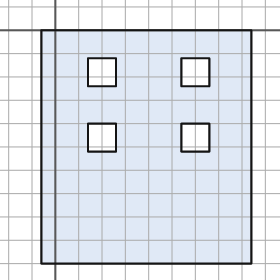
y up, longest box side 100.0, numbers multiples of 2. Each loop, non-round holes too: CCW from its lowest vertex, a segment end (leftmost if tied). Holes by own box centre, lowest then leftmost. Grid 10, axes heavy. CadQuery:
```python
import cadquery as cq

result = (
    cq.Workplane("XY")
    .moveTo(-6.0, -100.0)
    .lineTo(84.0, -100.0)
    .lineTo(84.0, 0.0)
    .lineTo(-6.0, 0.0)
    .close()
    .moveTo(14.0, -52.0)
    .lineTo(26.0, -52.0)
    .lineTo(26.0, -40.0)
    .lineTo(14.0, -40.0)
    .close()
    .moveTo(54.0, -52.0)
    .lineTo(66.0, -52.0)
    .lineTo(66.0, -40.0)
    .lineTo(54.0, -40.0)
    .close()
    .moveTo(14.0, -24.0)
    .lineTo(26.0, -24.0)
    .lineTo(26.0, -12.0)
    .lineTo(14.0, -12.0)
    .close()
    .moveTo(54.0, -24.0)
    .lineTo(66.0, -24.0)
    .lineTo(66.0, -12.0)
    .lineTo(54.0, -12.0)
    .close()
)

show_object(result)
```